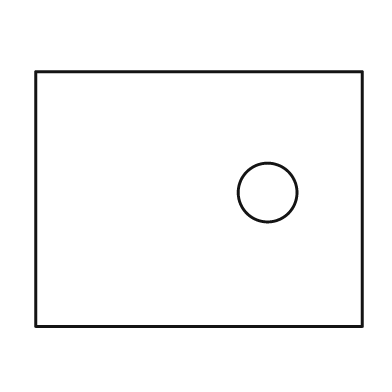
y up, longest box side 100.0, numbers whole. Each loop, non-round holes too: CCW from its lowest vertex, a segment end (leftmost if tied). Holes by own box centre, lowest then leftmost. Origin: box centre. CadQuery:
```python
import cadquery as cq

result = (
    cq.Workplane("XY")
    .moveTo(-50.0, -39.0)
    .lineTo(50.0, -39.0)
    .lineTo(50.0, 39.0)
    .lineTo(-50.0, 39.0)
    .close()
    .moveTo(21.0, 2.0)
    .circle(9.0)
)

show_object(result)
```